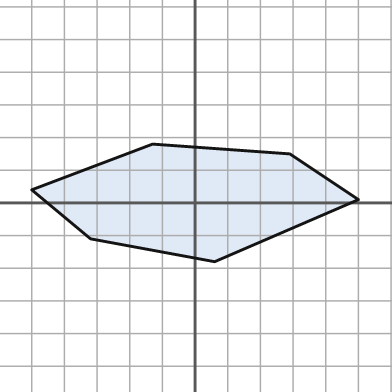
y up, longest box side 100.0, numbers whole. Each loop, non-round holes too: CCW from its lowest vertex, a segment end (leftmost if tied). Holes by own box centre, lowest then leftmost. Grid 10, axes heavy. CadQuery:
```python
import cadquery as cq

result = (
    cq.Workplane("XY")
    .moveTo(6.0, -18.0)
    .lineTo(50.0, 1.0)
    .lineTo(29.0, 15.0)
    .lineTo(-13.0, 18.0)
    .lineTo(-50.0, 4.0)
    .lineTo(-32.0, -11.0)
    .close()
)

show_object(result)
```